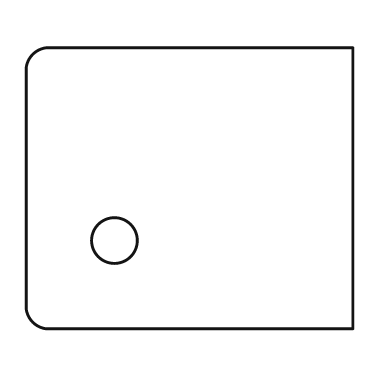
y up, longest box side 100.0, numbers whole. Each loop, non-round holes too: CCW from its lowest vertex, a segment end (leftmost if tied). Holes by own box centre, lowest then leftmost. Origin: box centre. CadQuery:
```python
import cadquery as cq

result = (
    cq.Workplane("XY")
    .moveTo(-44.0, -43.0)
    .lineTo(50.0, -43.0)
    .lineTo(50.0, 43.0)
    .lineTo(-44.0, 43.0)
    .threePointArc((-48.0, 41.0), (-50.0, 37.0))
    .lineTo(-50.0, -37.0)
    .threePointArc((-48.0, -41.0), (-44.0, -43.0))
    .close()
    .moveTo(-23.0, -16.0)
    .circle(7.0)
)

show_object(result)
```